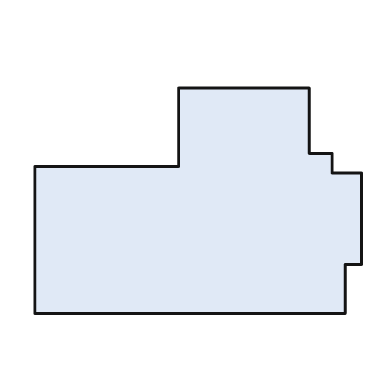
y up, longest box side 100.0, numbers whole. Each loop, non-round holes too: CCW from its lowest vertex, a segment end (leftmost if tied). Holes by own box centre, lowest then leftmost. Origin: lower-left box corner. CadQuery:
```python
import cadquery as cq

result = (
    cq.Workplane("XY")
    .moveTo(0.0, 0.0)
    .lineTo(95.0, 0.0)
    .lineTo(95.0, 15.0)
    .lineTo(100.0, 15.0)
    .lineTo(100.0, 43.0)
    .lineTo(91.0, 43.0)
    .lineTo(91.0, 49.0)
    .lineTo(84.0, 49.0)
    .lineTo(84.0, 69.0)
    .lineTo(44.0, 69.0)
    .lineTo(44.0, 45.0)
    .lineTo(0.0, 45.0)
    .close()
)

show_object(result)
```